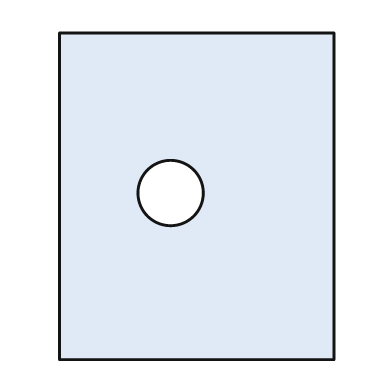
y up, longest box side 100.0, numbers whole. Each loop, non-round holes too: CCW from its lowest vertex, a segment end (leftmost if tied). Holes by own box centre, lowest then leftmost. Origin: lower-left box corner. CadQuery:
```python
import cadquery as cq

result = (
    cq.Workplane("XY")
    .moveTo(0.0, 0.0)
    .lineTo(84.0, 0.0)
    .lineTo(84.0, 100.0)
    .lineTo(0.0, 100.0)
    .close()
    .moveTo(34.0, 51.0)
    .circle(10.0)
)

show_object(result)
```